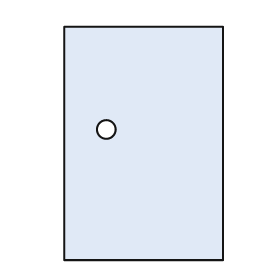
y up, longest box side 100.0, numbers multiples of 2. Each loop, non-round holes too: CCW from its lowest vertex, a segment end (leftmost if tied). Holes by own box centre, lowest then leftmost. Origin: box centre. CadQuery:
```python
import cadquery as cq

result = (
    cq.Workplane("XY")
    .moveTo(-34.0, -50.0)
    .lineTo(34.0, -50.0)
    .lineTo(34.0, 50.0)
    .lineTo(-34.0, 50.0)
    .close()
    .moveTo(-16.0, 6.0)
    .circle(4.0)
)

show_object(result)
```